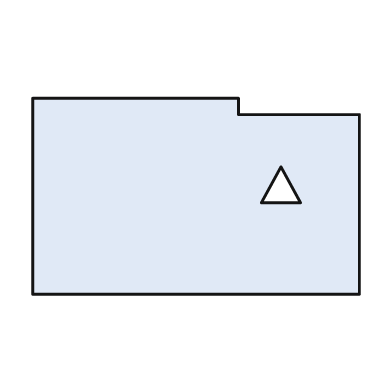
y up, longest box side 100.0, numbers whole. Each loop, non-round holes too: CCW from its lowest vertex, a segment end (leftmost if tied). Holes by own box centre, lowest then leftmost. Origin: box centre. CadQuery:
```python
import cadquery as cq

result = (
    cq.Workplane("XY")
    .moveTo(-50.0, -30.0)
    .lineTo(50.0, -30.0)
    .lineTo(50.0, 25.0)
    .lineTo(13.0, 25.0)
    .lineTo(13.0, 30.0)
    .lineTo(-50.0, 30.0)
    .close()
    .moveTo(20.0, -2.0)
    .lineTo(32.0, -2.0)
    .lineTo(26.0, 9.0)
    .close()
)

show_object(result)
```